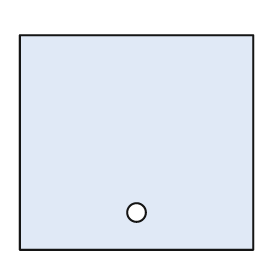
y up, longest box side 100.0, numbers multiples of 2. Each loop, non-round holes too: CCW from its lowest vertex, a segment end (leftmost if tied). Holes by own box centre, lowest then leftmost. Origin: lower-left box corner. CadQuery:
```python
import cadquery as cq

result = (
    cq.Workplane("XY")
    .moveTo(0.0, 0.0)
    .lineTo(100.0, 0.0)
    .lineTo(100.0, 92.0)
    .lineTo(0.0, 92.0)
    .close()
    .moveTo(50.0, 16.0)
    .circle(4.0)
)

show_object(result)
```